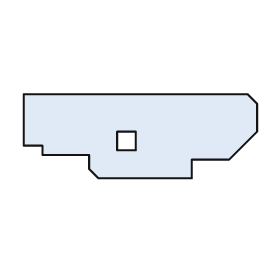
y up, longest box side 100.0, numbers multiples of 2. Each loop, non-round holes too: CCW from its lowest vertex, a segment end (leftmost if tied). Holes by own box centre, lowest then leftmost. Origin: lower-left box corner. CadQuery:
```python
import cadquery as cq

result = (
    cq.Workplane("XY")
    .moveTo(32.0, 0.0)
    .lineTo(72.0, 0.0)
    .lineTo(72.0, 8.0)
    .lineTo(88.0, 8.0)
    .lineTo(100.0, 20.0)
    .lineTo(100.0, 32.0)
    .lineTo(96.0, 36.0)
    .lineTo(0.0, 36.0)
    .lineTo(0.0, 14.0)
    .lineTo(8.0, 14.0)
    .lineTo(8.0, 10.0)
    .lineTo(28.0, 10.0)
    .lineTo(28.0, 4.0)
    .close()
    .moveTo(40.0, 12.0)
    .lineTo(48.0, 12.0)
    .lineTo(48.0, 20.0)
    .lineTo(40.0, 20.0)
    .close()
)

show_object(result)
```